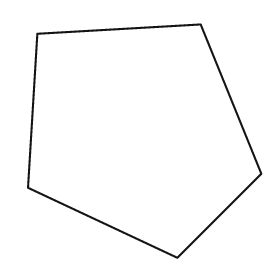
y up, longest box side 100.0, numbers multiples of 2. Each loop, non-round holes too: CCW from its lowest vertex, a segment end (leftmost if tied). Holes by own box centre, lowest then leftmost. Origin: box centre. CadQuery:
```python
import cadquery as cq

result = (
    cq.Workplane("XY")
    .moveTo(14.0, -50.0)
    .lineTo(50.0, -14.0)
    .lineTo(24.0, 50.0)
    .lineTo(-46.0, 46.0)
    .lineTo(-50.0, -20.0)
    .close()
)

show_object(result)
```